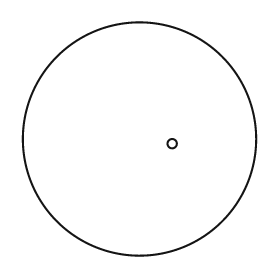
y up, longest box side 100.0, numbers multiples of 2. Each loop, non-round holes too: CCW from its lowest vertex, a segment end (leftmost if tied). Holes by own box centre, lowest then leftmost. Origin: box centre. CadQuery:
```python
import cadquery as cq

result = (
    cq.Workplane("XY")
    .moveTo(0.0, 0.0)
    .circle(50.0)
    .moveTo(14.0, -2.0)
    .circle(2.0)
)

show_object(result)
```